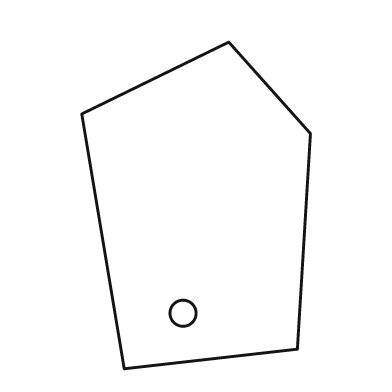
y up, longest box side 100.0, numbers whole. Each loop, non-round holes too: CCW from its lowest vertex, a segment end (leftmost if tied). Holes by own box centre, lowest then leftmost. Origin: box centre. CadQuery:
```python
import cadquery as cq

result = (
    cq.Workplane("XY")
    .moveTo(-22.0, -50.0)
    .lineTo(31.0, -44.0)
    .lineTo(35.0, 22.0)
    .lineTo(10.0, 50.0)
    .lineTo(-35.0, 28.0)
    .close()
    .moveTo(-4.0, -33.0)
    .circle(4.0)
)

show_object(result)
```